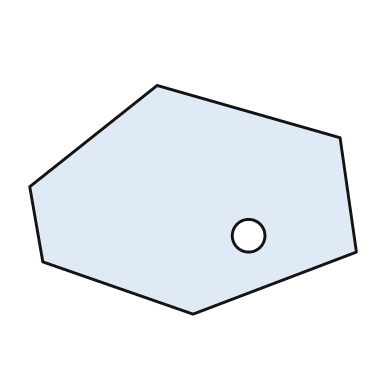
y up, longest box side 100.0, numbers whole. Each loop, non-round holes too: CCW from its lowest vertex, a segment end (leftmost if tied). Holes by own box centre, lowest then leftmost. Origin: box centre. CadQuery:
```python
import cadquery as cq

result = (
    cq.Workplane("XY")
    .moveTo(0.0, -35.0)
    .lineTo(50.0, -16.0)
    .lineTo(45.0, 19.0)
    .lineTo(-11.0, 35.0)
    .lineTo(-50.0, 4.0)
    .lineTo(-46.0, -19.0)
    .close()
    .moveTo(17.0, -11.0)
    .circle(5.0)
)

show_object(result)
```